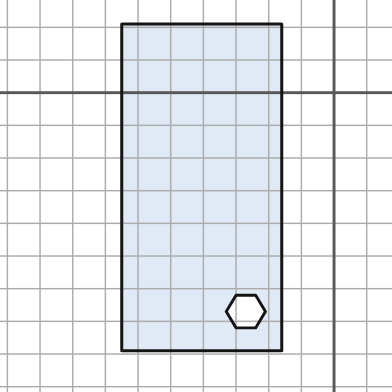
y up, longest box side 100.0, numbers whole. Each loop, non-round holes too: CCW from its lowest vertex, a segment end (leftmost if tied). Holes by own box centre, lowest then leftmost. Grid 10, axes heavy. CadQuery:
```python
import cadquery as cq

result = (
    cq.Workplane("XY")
    .moveTo(-65.0, -79.0)
    .lineTo(-16.0, -79.0)
    .lineTo(-16.0, 21.0)
    .lineTo(-65.0, 21.0)
    .close()
    .moveTo(-30.0, -72.0)
    .lineTo(-24.0, -72.0)
    .lineTo(-21.0, -67.0)
    .lineTo(-24.0, -62.0)
    .lineTo(-30.0, -62.0)
    .lineTo(-33.0, -67.0)
    .close()
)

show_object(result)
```